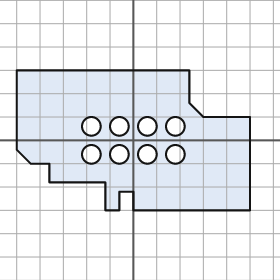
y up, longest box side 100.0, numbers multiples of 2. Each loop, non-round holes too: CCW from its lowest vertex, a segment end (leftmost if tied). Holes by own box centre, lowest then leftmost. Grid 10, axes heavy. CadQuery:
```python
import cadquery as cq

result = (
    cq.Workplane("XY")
    .moveTo(-12.0, -30.0)
    .lineTo(-6.0, -30.0)
    .lineTo(-6.0, -22.0)
    .lineTo(0.0, -22.0)
    .lineTo(0.0, -30.0)
    .lineTo(50.0, -30.0)
    .lineTo(50.0, 10.0)
    .lineTo(30.0, 10.0)
    .lineTo(24.0, 16.0)
    .lineTo(24.0, 30.0)
    .lineTo(-50.0, 30.0)
    .lineTo(-50.0, -4.0)
    .lineTo(-44.0, -10.0)
    .lineTo(-36.0, -10.0)
    .lineTo(-36.0, -18.0)
    .lineTo(-12.0, -18.0)
    .close()
    .moveTo(-18.0, -6.0)
    .circle(4.0)
    .moveTo(-6.0, -6.0)
    .circle(4.0)
    .moveTo(6.0, -6.0)
    .circle(4.0)
    .moveTo(18.0, -6.0)
    .circle(4.0)
    .moveTo(-18.0, 6.0)
    .circle(4.0)
    .moveTo(-6.0, 6.0)
    .circle(4.0)
    .moveTo(6.0, 6.0)
    .circle(4.0)
    .moveTo(18.0, 6.0)
    .circle(4.0)
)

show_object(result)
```